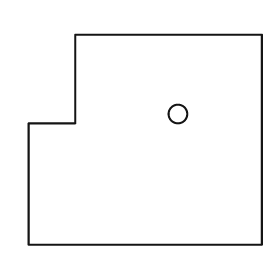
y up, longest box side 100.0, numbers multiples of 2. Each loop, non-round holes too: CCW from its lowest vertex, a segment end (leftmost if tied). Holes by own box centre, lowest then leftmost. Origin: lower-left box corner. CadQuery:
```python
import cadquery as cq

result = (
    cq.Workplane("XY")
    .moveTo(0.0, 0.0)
    .lineTo(100.0, 0.0)
    .lineTo(100.0, 90.0)
    .lineTo(20.0, 90.0)
    .lineTo(20.0, 52.0)
    .lineTo(0.0, 52.0)
    .close()
    .moveTo(64.0, 56.0)
    .circle(4.0)
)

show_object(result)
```